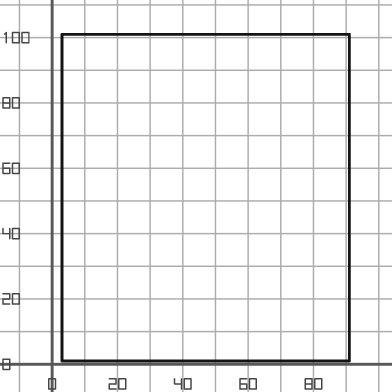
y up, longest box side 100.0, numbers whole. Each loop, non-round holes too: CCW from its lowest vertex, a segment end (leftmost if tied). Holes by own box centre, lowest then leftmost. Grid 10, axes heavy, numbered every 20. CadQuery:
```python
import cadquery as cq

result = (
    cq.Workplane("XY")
    .moveTo(3.0, 1.0)
    .lineTo(91.0, 1.0)
    .lineTo(91.0, 101.0)
    .lineTo(3.0, 101.0)
    .close()
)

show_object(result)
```